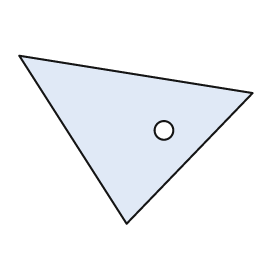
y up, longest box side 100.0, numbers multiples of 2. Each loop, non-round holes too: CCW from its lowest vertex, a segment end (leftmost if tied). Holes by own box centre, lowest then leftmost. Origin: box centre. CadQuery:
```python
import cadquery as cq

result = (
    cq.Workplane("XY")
    .moveTo(-4.0, -36.0)
    .lineTo(50.0, 20.0)
    .lineTo(-50.0, 36.0)
    .close()
    .moveTo(12.0, 4.0)
    .circle(4.0)
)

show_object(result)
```